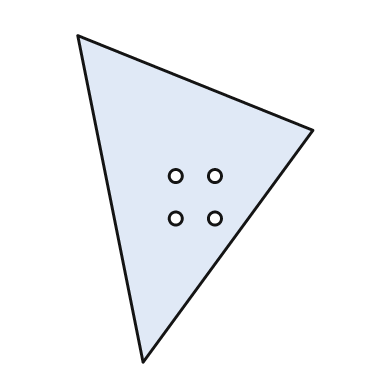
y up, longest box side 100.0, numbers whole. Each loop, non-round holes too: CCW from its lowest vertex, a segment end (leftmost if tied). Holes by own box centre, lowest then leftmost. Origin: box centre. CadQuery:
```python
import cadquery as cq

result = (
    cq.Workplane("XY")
    .moveTo(-16.0, -50.0)
    .lineTo(36.0, 21.0)
    .lineTo(-36.0, 50.0)
    .close()
    .moveTo(-6.0, -6.0)
    .circle(2.0)
    .moveTo(6.0, -6.0)
    .circle(2.0)
    .moveTo(-6.0, 7.0)
    .circle(2.0)
    .moveTo(6.0, 7.0)
    .circle(2.0)
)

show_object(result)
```